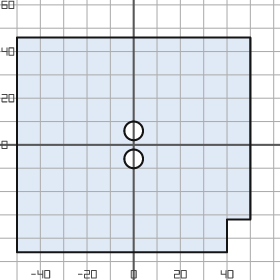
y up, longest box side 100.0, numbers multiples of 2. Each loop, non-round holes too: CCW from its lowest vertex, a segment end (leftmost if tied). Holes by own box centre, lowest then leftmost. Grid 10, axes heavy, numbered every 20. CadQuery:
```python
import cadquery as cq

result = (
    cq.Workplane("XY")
    .moveTo(-50.0, -46.0)
    .lineTo(40.0, -46.0)
    .lineTo(40.0, -32.0)
    .lineTo(50.0, -32.0)
    .lineTo(50.0, 46.0)
    .lineTo(-50.0, 46.0)
    .close()
    .moveTo(0.0, -6.0)
    .circle(4.0)
    .moveTo(0.0, 6.0)
    .circle(4.0)
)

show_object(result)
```